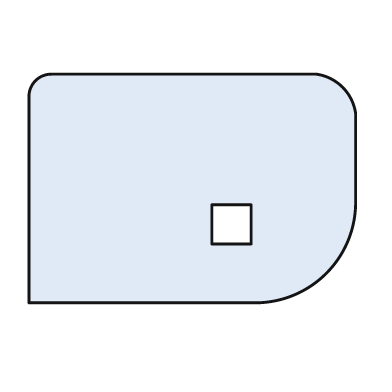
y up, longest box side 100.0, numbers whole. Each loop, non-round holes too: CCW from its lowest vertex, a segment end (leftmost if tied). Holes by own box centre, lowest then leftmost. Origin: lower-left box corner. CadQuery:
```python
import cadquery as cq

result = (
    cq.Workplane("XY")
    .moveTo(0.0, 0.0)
    .lineTo(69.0, 0.0)
    .threePointArc((91.0, 9.0), (100.0, 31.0))
    .lineTo(100.0, 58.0)
    .threePointArc((96.0, 66.0), (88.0, 70.0))
    .lineTo(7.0, 70.0)
    .threePointArc((2.0, 68.0), (0.0, 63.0))
    .close()
    .moveTo(56.0, 18.0)
    .lineTo(68.0, 18.0)
    .lineTo(68.0, 30.0)
    .lineTo(56.0, 30.0)
    .close()
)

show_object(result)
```